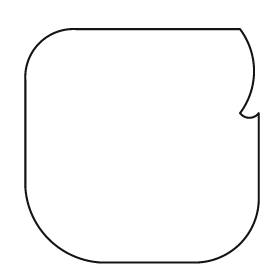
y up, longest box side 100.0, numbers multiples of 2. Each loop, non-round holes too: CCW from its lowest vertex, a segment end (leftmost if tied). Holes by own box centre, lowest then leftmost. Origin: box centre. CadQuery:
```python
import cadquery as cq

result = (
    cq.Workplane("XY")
    .moveTo(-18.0, -50.0)
    .lineTo(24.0, -50.0)
    .threePointArc((42.0, -42.0), (50.0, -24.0))
    .lineTo(50.0, 14.0)
    .threePointArc((46.0, 12.0), (42.0, 14.0))
    .threePointArc((48.0, 32.0), (42.0, 50.0))
    .lineTo(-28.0, 50.0)
    .threePointArc((-44.0, 44.0), (-50.0, 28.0))
    .lineTo(-50.0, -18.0)
    .threePointArc((-40.0, -40.0), (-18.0, -50.0))
    .close()
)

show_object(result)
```